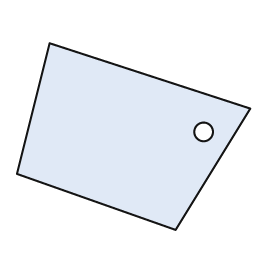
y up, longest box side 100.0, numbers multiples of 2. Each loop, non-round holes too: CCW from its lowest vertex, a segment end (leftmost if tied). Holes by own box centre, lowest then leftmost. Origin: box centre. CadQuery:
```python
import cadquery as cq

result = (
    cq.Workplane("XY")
    .moveTo(18.0, -40.0)
    .lineTo(50.0, 12.0)
    .lineTo(-36.0, 40.0)
    .lineTo(-50.0, -16.0)
    .close()
    .moveTo(30.0, 2.0)
    .circle(4.0)
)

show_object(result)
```